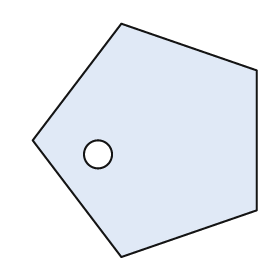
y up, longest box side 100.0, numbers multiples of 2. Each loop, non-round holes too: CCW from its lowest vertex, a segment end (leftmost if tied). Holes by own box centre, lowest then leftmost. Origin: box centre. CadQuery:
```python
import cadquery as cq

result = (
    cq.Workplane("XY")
    .moveTo(-10.0, -50.0)
    .lineTo(48.0, -30.0)
    .lineTo(48.0, 30.0)
    .lineTo(-10.0, 50.0)
    .lineTo(-48.0, 0.0)
    .close()
    .moveTo(-20.0, -6.0)
    .circle(6.0)
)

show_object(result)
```